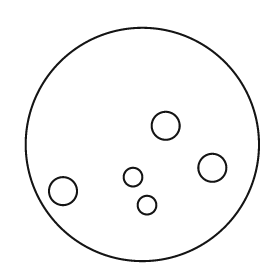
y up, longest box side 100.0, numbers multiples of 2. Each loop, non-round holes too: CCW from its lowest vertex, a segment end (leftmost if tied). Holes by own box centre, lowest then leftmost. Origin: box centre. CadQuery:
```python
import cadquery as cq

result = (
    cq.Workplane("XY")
    .moveTo(0.0, 0.0)
    .circle(50.0)
    .moveTo(2.0, -26.0)
    .circle(4.0)
    .moveTo(-34.0, -20.0)
    .circle(6.0)
    .moveTo(-4.0, -14.0)
    .circle(4.0)
    .moveTo(30.0, -10.0)
    .circle(6.0)
    .moveTo(10.0, 8.0)
    .circle(6.0)
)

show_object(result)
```